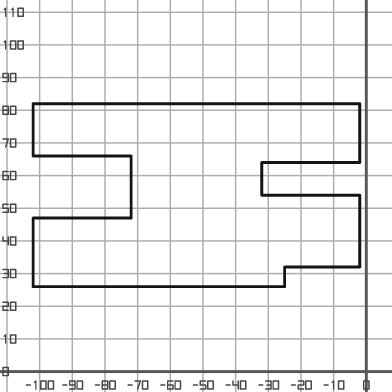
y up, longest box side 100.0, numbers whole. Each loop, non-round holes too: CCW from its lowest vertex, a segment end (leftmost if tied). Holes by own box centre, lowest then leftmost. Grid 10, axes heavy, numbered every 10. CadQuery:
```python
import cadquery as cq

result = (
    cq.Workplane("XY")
    .moveTo(-102.0, 26.0)
    .lineTo(-25.0, 26.0)
    .lineTo(-25.0, 32.0)
    .lineTo(-2.0, 32.0)
    .lineTo(-2.0, 54.0)
    .lineTo(-32.0, 54.0)
    .lineTo(-32.0, 64.0)
    .lineTo(-2.0, 64.0)
    .lineTo(-2.0, 82.0)
    .lineTo(-102.0, 82.0)
    .lineTo(-102.0, 66.0)
    .lineTo(-72.0, 66.0)
    .lineTo(-72.0, 47.0)
    .lineTo(-102.0, 47.0)
    .close()
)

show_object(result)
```